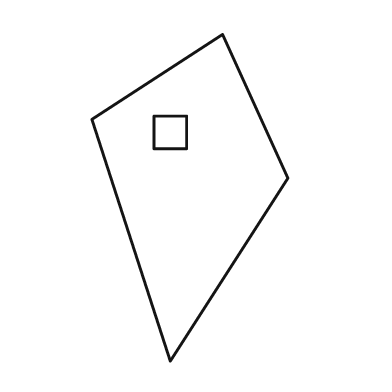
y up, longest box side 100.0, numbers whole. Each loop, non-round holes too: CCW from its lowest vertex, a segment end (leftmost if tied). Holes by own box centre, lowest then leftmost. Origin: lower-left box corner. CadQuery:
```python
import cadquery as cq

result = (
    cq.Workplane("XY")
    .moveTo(24.0, 0.0)
    .lineTo(60.0, 56.0)
    .lineTo(40.0, 100.0)
    .lineTo(0.0, 74.0)
    .close()
    .moveTo(19.0, 65.0)
    .lineTo(29.0, 65.0)
    .lineTo(29.0, 75.0)
    .lineTo(19.0, 75.0)
    .close()
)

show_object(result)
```